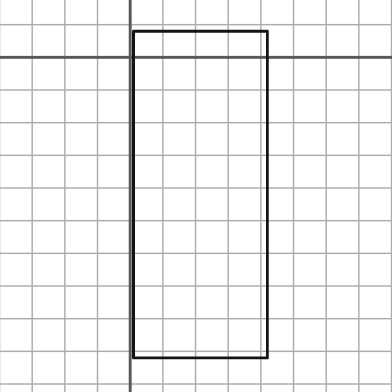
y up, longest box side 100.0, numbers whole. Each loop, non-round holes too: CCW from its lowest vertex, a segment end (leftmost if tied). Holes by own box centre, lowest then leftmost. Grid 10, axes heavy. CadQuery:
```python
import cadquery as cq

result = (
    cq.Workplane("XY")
    .moveTo(1.0, -92.0)
    .lineTo(42.0, -92.0)
    .lineTo(42.0, 8.0)
    .lineTo(1.0, 8.0)
    .close()
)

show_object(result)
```